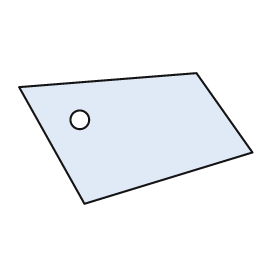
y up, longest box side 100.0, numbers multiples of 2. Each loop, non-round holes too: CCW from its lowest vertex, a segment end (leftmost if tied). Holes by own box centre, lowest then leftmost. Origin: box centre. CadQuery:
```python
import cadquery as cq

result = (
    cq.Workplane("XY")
    .moveTo(-22.0, -28.0)
    .lineTo(50.0, -6.0)
    .lineTo(26.0, 28.0)
    .lineTo(-50.0, 22.0)
    .close()
    .moveTo(-24.0, 8.0)
    .circle(4.0)
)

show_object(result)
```